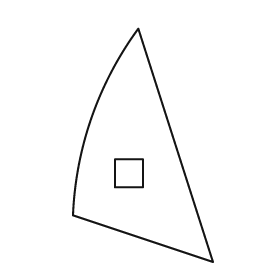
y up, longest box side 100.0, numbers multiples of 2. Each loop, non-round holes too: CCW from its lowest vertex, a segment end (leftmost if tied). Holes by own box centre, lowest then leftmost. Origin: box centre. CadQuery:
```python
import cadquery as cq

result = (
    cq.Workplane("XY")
    .moveTo(30.0, -50.0)
    .lineTo(-2.0, 50.0)
    .threePointArc((-22.0, 12.0), (-30.0, -30.0))
    .close()
    .moveTo(-12.0, -18.0)
    .lineTo(0.0, -18.0)
    .lineTo(0.0, -6.0)
    .lineTo(-12.0, -6.0)
    .close()
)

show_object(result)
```